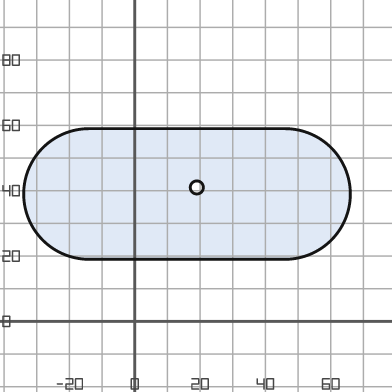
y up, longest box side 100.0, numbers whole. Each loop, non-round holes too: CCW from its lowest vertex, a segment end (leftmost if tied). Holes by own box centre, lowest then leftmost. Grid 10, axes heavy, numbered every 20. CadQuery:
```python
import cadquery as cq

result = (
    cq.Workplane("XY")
    .moveTo(-14.0, 19.0)
    .lineTo(46.0, 19.0)
    .threePointArc((66.0, 39.0), (46.0, 59.0))
    .lineTo(-14.0, 59.0)
    .threePointArc((-34.0, 39.0), (-14.0, 19.0))
    .close()
    .moveTo(19.0, 41.0)
    .circle(2.0)
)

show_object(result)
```